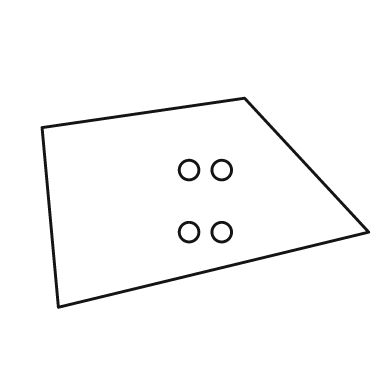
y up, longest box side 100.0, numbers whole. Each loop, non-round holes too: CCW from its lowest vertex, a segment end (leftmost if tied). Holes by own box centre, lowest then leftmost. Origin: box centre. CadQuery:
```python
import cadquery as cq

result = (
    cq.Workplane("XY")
    .moveTo(-45.0, -32.0)
    .lineTo(50.0, -9.0)
    .lineTo(12.0, 32.0)
    .lineTo(-50.0, 23.0)
    .close()
    .moveTo(-5.0, -9.0)
    .circle(3.0)
    .moveTo(5.0, -9.0)
    .circle(3.0)
    .moveTo(-5.0, 10.0)
    .circle(3.0)
    .moveTo(5.0, 10.0)
    .circle(3.0)
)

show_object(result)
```